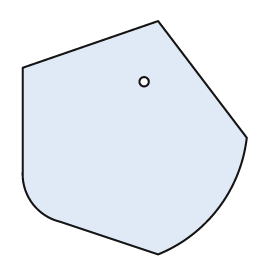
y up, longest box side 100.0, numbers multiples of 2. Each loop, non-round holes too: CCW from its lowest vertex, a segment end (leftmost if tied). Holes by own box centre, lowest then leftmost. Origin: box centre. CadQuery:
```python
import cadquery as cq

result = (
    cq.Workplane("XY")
    .moveTo(10.0, -50.0)
    .threePointArc((36.0, -30.0), (48.0, 0.0))
    .lineTo(10.0, 50.0)
    .lineTo(-48.0, 30.0)
    .lineTo(-48.0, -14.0)
    .threePointArc((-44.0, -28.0), (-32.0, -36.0))
    .close()
    .moveTo(4.0, 24.0)
    .circle(2.0)
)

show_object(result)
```